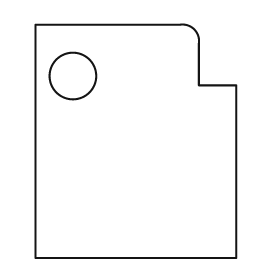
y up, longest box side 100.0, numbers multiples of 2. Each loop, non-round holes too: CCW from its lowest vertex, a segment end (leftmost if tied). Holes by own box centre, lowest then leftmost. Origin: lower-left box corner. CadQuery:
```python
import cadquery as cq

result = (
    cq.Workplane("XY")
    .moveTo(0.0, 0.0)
    .lineTo(86.0, 0.0)
    .lineTo(86.0, 74.0)
    .lineTo(70.0, 74.0)
    .lineTo(70.0, 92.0)
    .threePointArc((68.0, 98.0), (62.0, 100.0))
    .lineTo(0.0, 100.0)
    .close()
    .moveTo(16.0, 78.0)
    .circle(10.0)
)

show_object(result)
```